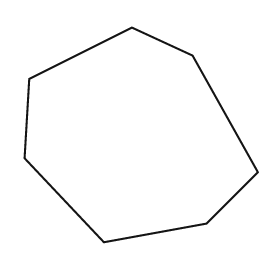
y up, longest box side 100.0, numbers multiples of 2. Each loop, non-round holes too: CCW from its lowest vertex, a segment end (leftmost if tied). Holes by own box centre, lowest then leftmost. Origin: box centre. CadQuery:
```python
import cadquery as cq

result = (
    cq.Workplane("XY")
    .moveTo(-16.0, -46.0)
    .lineTo(28.0, -38.0)
    .lineTo(50.0, -16.0)
    .lineTo(22.0, 34.0)
    .lineTo(-4.0, 46.0)
    .lineTo(-48.0, 24.0)
    .lineTo(-50.0, -10.0)
    .close()
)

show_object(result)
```